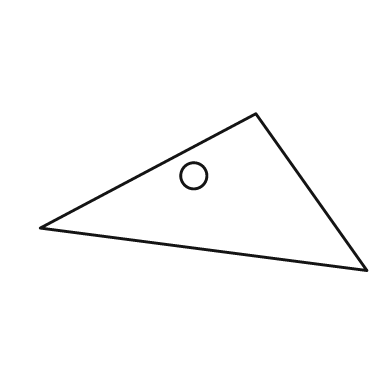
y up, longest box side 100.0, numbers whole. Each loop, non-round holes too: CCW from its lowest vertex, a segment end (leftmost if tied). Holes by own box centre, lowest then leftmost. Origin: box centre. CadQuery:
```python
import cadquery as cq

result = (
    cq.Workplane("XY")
    .moveTo(50.0, -24.0)
    .lineTo(16.0, 24.0)
    .lineTo(-50.0, -11.0)
    .close()
    .moveTo(-3.0, 5.0)
    .circle(4.0)
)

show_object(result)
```